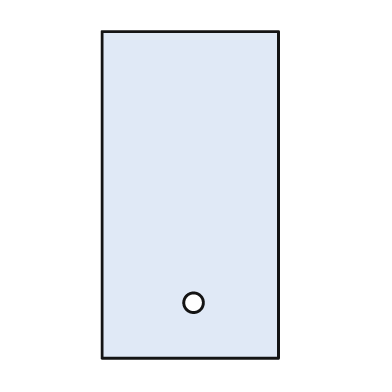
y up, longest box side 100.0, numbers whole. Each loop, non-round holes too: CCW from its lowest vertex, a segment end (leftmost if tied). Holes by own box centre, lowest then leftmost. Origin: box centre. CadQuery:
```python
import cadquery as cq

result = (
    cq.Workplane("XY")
    .moveTo(-27.0, -50.0)
    .lineTo(27.0, -50.0)
    .lineTo(27.0, 50.0)
    .lineTo(-27.0, 50.0)
    .close()
    .moveTo(1.0, -33.0)
    .circle(3.0)
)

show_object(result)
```